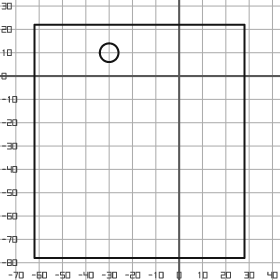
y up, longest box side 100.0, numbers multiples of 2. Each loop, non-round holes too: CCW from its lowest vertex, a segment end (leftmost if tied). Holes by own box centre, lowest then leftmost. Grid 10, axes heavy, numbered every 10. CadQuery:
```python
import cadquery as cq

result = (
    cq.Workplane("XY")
    .moveTo(-62.0, -78.0)
    .lineTo(28.0, -78.0)
    .lineTo(28.0, 22.0)
    .lineTo(-62.0, 22.0)
    .close()
    .moveTo(-30.0, 10.0)
    .circle(4.0)
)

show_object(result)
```